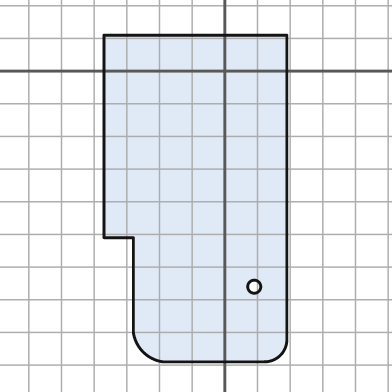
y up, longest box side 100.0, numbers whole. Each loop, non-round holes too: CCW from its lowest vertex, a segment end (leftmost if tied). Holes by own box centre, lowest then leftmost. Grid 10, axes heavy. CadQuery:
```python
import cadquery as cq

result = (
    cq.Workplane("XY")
    .moveTo(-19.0, -89.0)
    .lineTo(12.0, -89.0)
    .threePointArc((17.0, -87.0), (19.0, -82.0))
    .lineTo(19.0, 11.0)
    .lineTo(-37.0, 11.0)
    .lineTo(-37.0, -51.0)
    .lineTo(-28.0, -51.0)
    .lineTo(-28.0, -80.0)
    .threePointArc((-25.0, -86.0), (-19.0, -89.0))
    .close()
    .moveTo(9.0, -66.0)
    .circle(2.0)
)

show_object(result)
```